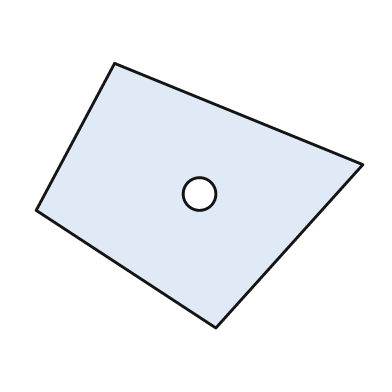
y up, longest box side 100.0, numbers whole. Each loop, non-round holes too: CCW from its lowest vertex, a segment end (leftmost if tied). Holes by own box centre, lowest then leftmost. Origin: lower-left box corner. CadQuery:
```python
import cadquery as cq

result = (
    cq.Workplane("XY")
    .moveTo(55.0, 0.0)
    .lineTo(100.0, 50.0)
    .lineTo(24.0, 81.0)
    .lineTo(0.0, 36.0)
    .close()
    .moveTo(50.0, 41.0)
    .circle(5.0)
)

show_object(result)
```